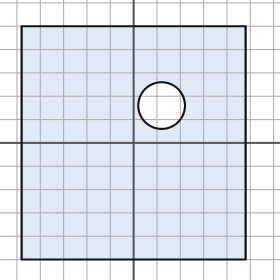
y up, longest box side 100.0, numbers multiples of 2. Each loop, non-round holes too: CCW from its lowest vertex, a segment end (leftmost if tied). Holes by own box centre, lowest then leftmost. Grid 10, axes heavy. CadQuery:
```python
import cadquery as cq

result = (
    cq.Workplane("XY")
    .moveTo(-48.0, -50.0)
    .lineTo(48.0, -50.0)
    .lineTo(48.0, 50.0)
    .lineTo(-48.0, 50.0)
    .close()
    .moveTo(12.0, 16.0)
    .circle(10.0)
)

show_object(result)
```